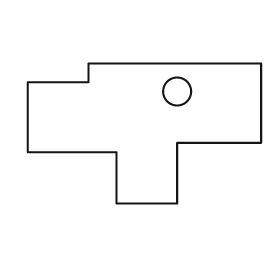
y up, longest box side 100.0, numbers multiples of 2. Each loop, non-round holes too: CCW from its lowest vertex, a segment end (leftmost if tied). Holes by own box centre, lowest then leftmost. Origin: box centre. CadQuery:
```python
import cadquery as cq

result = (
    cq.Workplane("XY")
    .moveTo(-12.0, -30.0)
    .lineTo(14.0, -30.0)
    .lineTo(14.0, -4.0)
    .lineTo(50.0, -4.0)
    .lineTo(50.0, 30.0)
    .lineTo(-24.0, 30.0)
    .lineTo(-24.0, 22.0)
    .lineTo(-50.0, 22.0)
    .lineTo(-50.0, -8.0)
    .lineTo(-12.0, -8.0)
    .close()
    .moveTo(14.0, 18.0)
    .circle(6.0)
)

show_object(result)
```